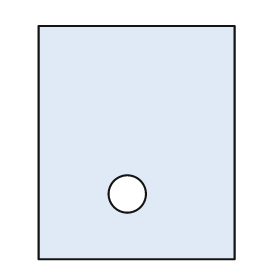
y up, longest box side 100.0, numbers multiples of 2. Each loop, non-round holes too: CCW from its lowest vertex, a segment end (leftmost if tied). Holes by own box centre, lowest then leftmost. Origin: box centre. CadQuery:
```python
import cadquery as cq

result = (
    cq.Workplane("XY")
    .moveTo(-42.0, -50.0)
    .lineTo(42.0, -50.0)
    .lineTo(42.0, 50.0)
    .lineTo(-42.0, 50.0)
    .close()
    .moveTo(-4.0, -22.0)
    .circle(8.0)
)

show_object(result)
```